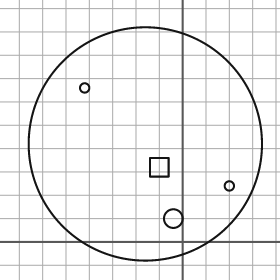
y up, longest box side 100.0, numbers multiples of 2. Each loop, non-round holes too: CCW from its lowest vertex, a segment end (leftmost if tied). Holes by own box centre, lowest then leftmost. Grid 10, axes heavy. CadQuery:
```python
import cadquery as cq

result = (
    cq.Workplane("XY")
    .moveTo(-16.0, 42.0)
    .circle(50.0)
    .moveTo(-4.0, 10.0)
    .circle(4.0)
    .moveTo(20.0, 24.0)
    .circle(2.0)
    .moveTo(-14.0, 28.0)
    .lineTo(-6.0, 28.0)
    .lineTo(-6.0, 36.0)
    .lineTo(-14.0, 36.0)
    .close()
    .moveTo(-42.0, 66.0)
    .circle(2.0)
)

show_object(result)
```